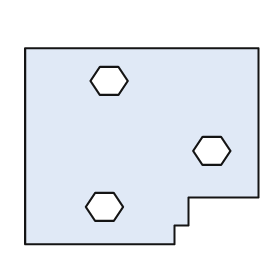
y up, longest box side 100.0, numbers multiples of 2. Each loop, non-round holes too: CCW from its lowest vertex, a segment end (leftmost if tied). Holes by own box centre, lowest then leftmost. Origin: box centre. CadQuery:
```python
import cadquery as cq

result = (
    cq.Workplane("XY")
    .moveTo(-50.0, -42.0)
    .lineTo(14.0, -42.0)
    .lineTo(14.0, -34.0)
    .lineTo(20.0, -34.0)
    .lineTo(20.0, -22.0)
    .lineTo(50.0, -22.0)
    .lineTo(50.0, 42.0)
    .lineTo(-50.0, 42.0)
    .close()
    .moveTo(-20.0, -32.0)
    .lineTo(-12.0, -32.0)
    .lineTo(-8.0, -26.0)
    .lineTo(-12.0, -20.0)
    .lineTo(-20.0, -20.0)
    .lineTo(-24.0, -26.0)
    .close()
    .moveTo(26.0, -8.0)
    .lineTo(34.0, -8.0)
    .lineTo(38.0, -2.0)
    .lineTo(34.0, 4.0)
    .lineTo(26.0, 4.0)
    .lineTo(22.0, -2.0)
    .close()
    .moveTo(-18.0, 22.0)
    .lineTo(-10.0, 22.0)
    .lineTo(-6.0, 28.0)
    .lineTo(-10.0, 34.0)
    .lineTo(-18.0, 34.0)
    .lineTo(-22.0, 28.0)
    .close()
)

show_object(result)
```